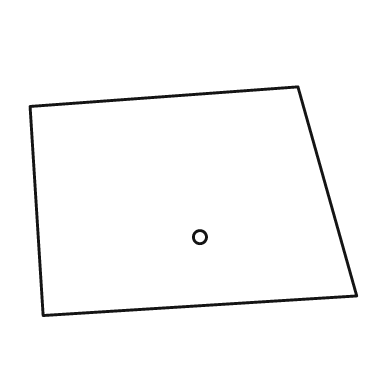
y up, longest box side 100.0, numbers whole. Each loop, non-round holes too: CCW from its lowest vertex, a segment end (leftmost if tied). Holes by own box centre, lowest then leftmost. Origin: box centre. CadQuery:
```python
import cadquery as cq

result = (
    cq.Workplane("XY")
    .moveTo(-46.0, -35.0)
    .lineTo(50.0, -29.0)
    .lineTo(32.0, 35.0)
    .lineTo(-50.0, 29.0)
    .close()
    .moveTo(2.0, -11.0)
    .circle(2.0)
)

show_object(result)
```